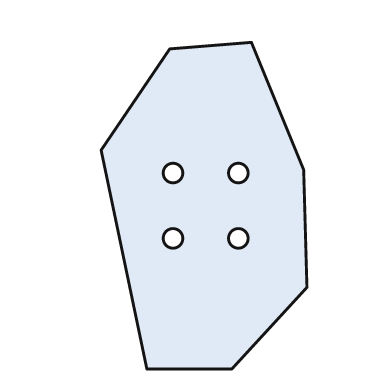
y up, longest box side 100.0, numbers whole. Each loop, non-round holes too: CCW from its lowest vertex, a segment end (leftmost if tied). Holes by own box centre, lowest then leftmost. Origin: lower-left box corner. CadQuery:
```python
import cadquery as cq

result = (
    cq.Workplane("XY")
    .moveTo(14.0, 0.0)
    .lineTo(40.0, 0.0)
    .lineTo(63.0, 25.0)
    .lineTo(62.0, 61.0)
    .lineTo(46.0, 100.0)
    .lineTo(21.0, 98.0)
    .lineTo(0.0, 67.0)
    .close()
    .moveTo(22.0, 40.0)
    .circle(3.0)
    .moveTo(42.0, 40.0)
    .circle(3.0)
    .moveTo(22.0, 60.0)
    .circle(3.0)
    .moveTo(42.0, 60.0)
    .circle(3.0)
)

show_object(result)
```